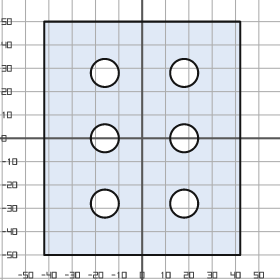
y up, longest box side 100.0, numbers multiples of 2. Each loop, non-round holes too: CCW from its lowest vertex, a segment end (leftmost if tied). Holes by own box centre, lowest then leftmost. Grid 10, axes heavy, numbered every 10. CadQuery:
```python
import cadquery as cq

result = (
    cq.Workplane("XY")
    .moveTo(-42.0, -50.0)
    .lineTo(42.0, -50.0)
    .lineTo(42.0, 50.0)
    .lineTo(-42.0, 50.0)
    .close()
    .moveTo(-16.0, -28.0)
    .circle(6.0)
    .moveTo(18.0, -28.0)
    .circle(6.0)
    .moveTo(-16.0, 0.0)
    .circle(6.0)
    .moveTo(18.0, 0.0)
    .circle(6.0)
    .moveTo(-16.0, 28.0)
    .circle(6.0)
    .moveTo(18.0, 28.0)
    .circle(6.0)
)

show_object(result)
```